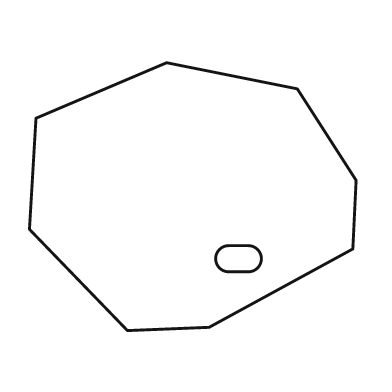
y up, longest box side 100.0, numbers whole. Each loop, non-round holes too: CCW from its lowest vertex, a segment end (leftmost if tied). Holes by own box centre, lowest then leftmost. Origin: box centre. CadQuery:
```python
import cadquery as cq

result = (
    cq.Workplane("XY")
    .moveTo(-20.0, -41.0)
    .lineTo(5.0, -40.0)
    .lineTo(49.0, -16.0)
    .lineTo(50.0, 5.0)
    .lineTo(32.0, 33.0)
    .lineTo(-8.0, 41.0)
    .lineTo(-48.0, 24.0)
    .lineTo(-50.0, -10.0)
    .close()
    .moveTo(11.0, -23.0)
    .lineTo(17.0, -23.0)
    .threePointArc((21.0, -19.0), (17.0, -15.0))
    .lineTo(11.0, -15.0)
    .threePointArc((7.0, -19.0), (11.0, -23.0))
    .close()
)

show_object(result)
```